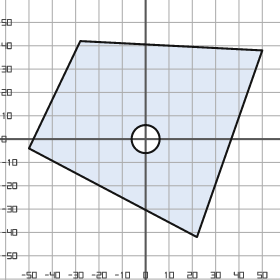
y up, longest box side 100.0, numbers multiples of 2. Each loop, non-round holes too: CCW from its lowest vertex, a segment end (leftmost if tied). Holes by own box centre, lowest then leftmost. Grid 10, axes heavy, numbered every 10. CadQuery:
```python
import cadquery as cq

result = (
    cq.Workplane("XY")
    .moveTo(22.0, -42.0)
    .lineTo(50.0, 38.0)
    .lineTo(-28.0, 42.0)
    .lineTo(-50.0, -4.0)
    .close()
    .moveTo(0.0, 0.0)
    .circle(6.0)
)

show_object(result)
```